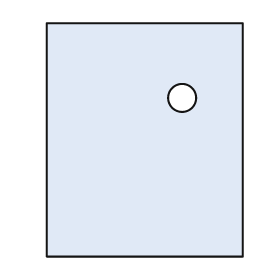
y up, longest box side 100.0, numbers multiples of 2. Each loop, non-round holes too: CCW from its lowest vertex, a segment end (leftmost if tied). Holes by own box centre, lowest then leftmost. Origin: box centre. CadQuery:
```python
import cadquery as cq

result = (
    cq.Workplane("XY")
    .moveTo(-42.0, -50.0)
    .lineTo(42.0, -50.0)
    .lineTo(42.0, 50.0)
    .lineTo(-42.0, 50.0)
    .close()
    .moveTo(16.0, 18.0)
    .circle(6.0)
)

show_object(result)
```